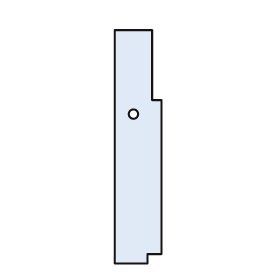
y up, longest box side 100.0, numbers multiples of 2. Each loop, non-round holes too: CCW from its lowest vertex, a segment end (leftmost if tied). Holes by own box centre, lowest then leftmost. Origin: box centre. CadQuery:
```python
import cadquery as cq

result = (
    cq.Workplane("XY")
    .moveTo(-10.0, -50.0)
    .lineTo(4.0, -50.0)
    .lineTo(4.0, -46.0)
    .lineTo(10.0, -46.0)
    .lineTo(10.0, 20.0)
    .lineTo(6.0, 20.0)
    .lineTo(6.0, 50.0)
    .lineTo(-10.0, 50.0)
    .close()
    .moveTo(-2.0, 14.0)
    .circle(2.0)
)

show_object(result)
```